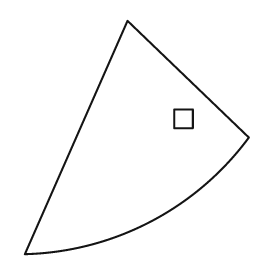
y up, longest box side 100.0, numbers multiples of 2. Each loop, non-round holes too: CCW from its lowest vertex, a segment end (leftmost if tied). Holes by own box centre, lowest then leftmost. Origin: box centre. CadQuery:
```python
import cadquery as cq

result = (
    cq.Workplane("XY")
    .moveTo(-48.0, -50.0)
    .threePointArc((6.0, -36.0), (48.0, 0.0))
    .lineTo(-4.0, 50.0)
    .close()
    .moveTo(16.0, 4.0)
    .lineTo(24.0, 4.0)
    .lineTo(24.0, 12.0)
    .lineTo(16.0, 12.0)
    .close()
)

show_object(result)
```